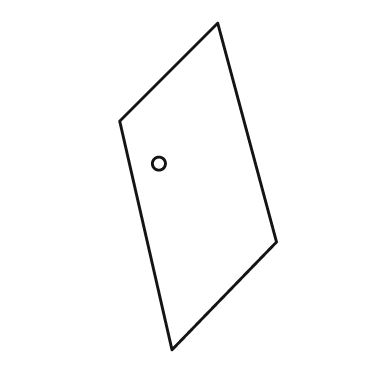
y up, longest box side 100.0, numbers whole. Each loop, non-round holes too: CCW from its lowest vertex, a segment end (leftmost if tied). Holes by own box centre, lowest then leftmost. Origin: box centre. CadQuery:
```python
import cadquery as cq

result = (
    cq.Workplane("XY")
    .moveTo(-8.0, -50.0)
    .lineTo(24.0, -17.0)
    .lineTo(6.0, 50.0)
    .lineTo(-24.0, 20.0)
    .close()
    .moveTo(-12.0, 7.0)
    .circle(2.0)
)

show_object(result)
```